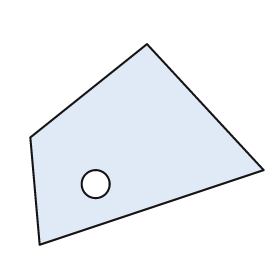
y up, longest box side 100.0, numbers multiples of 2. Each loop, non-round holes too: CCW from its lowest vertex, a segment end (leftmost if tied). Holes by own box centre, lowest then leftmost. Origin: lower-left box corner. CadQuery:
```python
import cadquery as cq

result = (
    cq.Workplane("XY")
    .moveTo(4.0, 0.0)
    .lineTo(100.0, 32.0)
    .lineTo(50.0, 86.0)
    .lineTo(0.0, 46.0)
    .close()
    .moveTo(28.0, 26.0)
    .circle(6.0)
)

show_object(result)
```